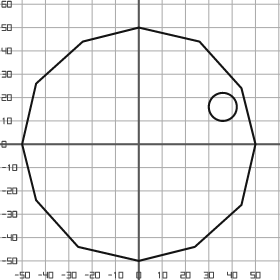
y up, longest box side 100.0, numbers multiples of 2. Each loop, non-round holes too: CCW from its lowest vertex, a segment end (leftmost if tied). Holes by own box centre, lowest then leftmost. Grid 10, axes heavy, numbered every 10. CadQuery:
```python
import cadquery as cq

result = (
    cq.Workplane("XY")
    .moveTo(0.0, -50.0)
    .lineTo(24.0, -44.0)
    .lineTo(44.0, -26.0)
    .lineTo(50.0, 0.0)
    .lineTo(44.0, 24.0)
    .lineTo(26.0, 44.0)
    .lineTo(0.0, 50.0)
    .lineTo(-24.0, 44.0)
    .lineTo(-44.0, 26.0)
    .lineTo(-50.0, 0.0)
    .lineTo(-44.0, -24.0)
    .lineTo(-26.0, -44.0)
    .close()
    .moveTo(36.0, 16.0)
    .circle(6.0)
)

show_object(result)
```